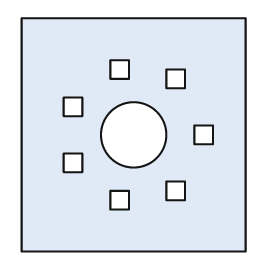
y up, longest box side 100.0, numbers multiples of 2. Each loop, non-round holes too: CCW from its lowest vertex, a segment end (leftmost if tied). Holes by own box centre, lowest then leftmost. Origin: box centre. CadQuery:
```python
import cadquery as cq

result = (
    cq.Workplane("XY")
    .moveTo(-48.0, -50.0)
    .lineTo(48.0, -50.0)
    .lineTo(48.0, 50.0)
    .lineTo(-48.0, 50.0)
    .close()
    .moveTo(-10.0, -32.0)
    .lineTo(-2.0, -32.0)
    .lineTo(-2.0, -24.0)
    .lineTo(-10.0, -24.0)
    .close()
    .moveTo(14.0, -28.0)
    .lineTo(22.0, -28.0)
    .lineTo(22.0, -20.0)
    .lineTo(14.0, -20.0)
    .close()
    .moveTo(-30.0, -16.0)
    .lineTo(-22.0, -16.0)
    .lineTo(-22.0, -8.0)
    .lineTo(-30.0, -8.0)
    .close()
    .moveTo(0.0, 0.0)
    .circle(14.0)
    .moveTo(26.0, -4.0)
    .lineTo(34.0, -4.0)
    .lineTo(34.0, 4.0)
    .lineTo(26.0, 4.0)
    .close()
    .moveTo(-30.0, 8.0)
    .lineTo(-22.0, 8.0)
    .lineTo(-22.0, 16.0)
    .lineTo(-30.0, 16.0)
    .close()
    .moveTo(14.0, 20.0)
    .lineTo(22.0, 20.0)
    .lineTo(22.0, 28.0)
    .lineTo(14.0, 28.0)
    .close()
    .moveTo(-10.0, 24.0)
    .lineTo(-2.0, 24.0)
    .lineTo(-2.0, 32.0)
    .lineTo(-10.0, 32.0)
    .close()
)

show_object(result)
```